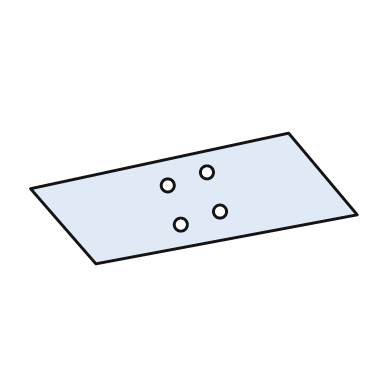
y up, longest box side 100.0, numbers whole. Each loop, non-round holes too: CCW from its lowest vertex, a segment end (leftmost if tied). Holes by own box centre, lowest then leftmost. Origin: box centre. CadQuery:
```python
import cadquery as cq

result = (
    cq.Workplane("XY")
    .moveTo(-30.0, -20.0)
    .lineTo(50.0, -5.0)
    .lineTo(29.0, 20.0)
    .lineTo(-50.0, 3.0)
    .close()
    .moveTo(-4.0, -8.0)
    .circle(2.0)
    .moveTo(8.0, -4.0)
    .circle(2.0)
    .moveTo(-8.0, 4.0)
    .circle(2.0)
    .moveTo(4.0, 8.0)
    .circle(2.0)
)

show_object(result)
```